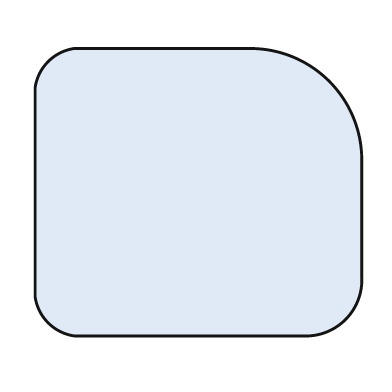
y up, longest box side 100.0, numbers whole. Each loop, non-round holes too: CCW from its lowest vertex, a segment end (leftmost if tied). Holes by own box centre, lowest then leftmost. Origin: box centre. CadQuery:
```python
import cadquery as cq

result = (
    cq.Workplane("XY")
    .moveTo(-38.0, -44.0)
    .lineTo(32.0, -44.0)
    .threePointArc((45.0, -39.0), (50.0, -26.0))
    .lineTo(50.0, 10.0)
    .threePointArc((40.0, 34.0), (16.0, 44.0))
    .lineTo(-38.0, 44.0)
    .threePointArc((-46.0, 40.0), (-50.0, 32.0))
    .lineTo(-50.0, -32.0)
    .threePointArc((-46.0, -40.0), (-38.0, -44.0))
    .close()
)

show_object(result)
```